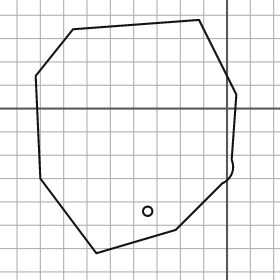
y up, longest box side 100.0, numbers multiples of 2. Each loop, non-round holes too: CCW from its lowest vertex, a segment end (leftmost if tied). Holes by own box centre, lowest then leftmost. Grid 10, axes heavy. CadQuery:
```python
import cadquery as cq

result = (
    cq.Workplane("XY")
    .moveTo(-56.0, -62.0)
    .lineTo(-22.0, -52.0)
    .lineTo(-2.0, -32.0)
    .threePointArc((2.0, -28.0), (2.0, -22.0))
    .lineTo(4.0, 6.0)
    .lineTo(-12.0, 38.0)
    .lineTo(-66.0, 34.0)
    .lineTo(-82.0, 14.0)
    .lineTo(-80.0, -30.0)
    .close()
    .moveTo(-34.0, -44.0)
    .circle(2.0)
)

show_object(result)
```